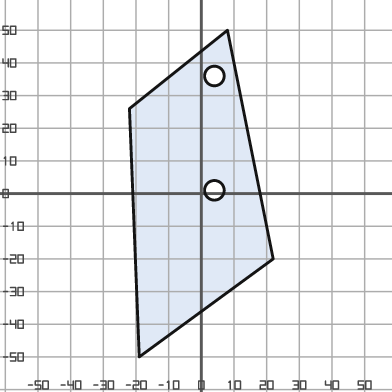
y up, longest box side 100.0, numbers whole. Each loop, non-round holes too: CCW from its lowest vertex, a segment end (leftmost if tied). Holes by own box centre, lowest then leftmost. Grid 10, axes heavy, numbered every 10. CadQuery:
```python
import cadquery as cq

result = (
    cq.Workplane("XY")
    .moveTo(-19.0, -50.0)
    .lineTo(22.0, -20.0)
    .lineTo(8.0, 50.0)
    .lineTo(-22.0, 26.0)
    .close()
    .moveTo(4.0, 1.0)
    .circle(3.0)
    .moveTo(4.0, 36.0)
    .circle(3.0)
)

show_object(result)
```